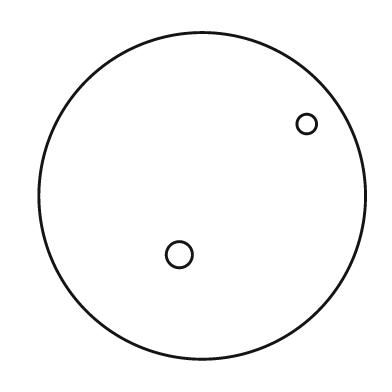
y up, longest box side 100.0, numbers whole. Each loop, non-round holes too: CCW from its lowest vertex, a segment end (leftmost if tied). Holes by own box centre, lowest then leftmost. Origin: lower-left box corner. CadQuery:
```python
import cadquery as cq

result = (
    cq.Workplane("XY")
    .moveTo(50.0, 50.0)
    .circle(50.0)
    .moveTo(43.0, 32.0)
    .circle(4.0)
    .moveTo(82.0, 72.0)
    .circle(3.0)
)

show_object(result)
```